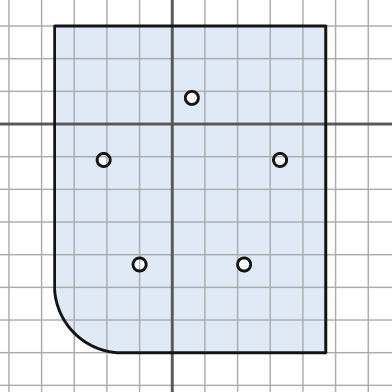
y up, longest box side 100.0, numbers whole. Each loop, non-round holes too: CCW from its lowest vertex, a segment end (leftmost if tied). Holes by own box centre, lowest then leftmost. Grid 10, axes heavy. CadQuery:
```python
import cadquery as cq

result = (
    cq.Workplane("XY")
    .moveTo(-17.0, -70.0)
    .lineTo(47.0, -70.0)
    .lineTo(47.0, 30.0)
    .lineTo(-36.0, 30.0)
    .lineTo(-36.0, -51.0)
    .threePointArc((-30.0, -64.0), (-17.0, -70.0))
    .close()
    .moveTo(-10.0, -43.0)
    .circle(2.0)
    .moveTo(22.0, -43.0)
    .circle(2.0)
    .moveTo(-21.0, -11.0)
    .circle(2.0)
    .moveTo(33.0, -11.0)
    .circle(2.0)
    .moveTo(6.0, 8.0)
    .circle(2.0)
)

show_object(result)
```